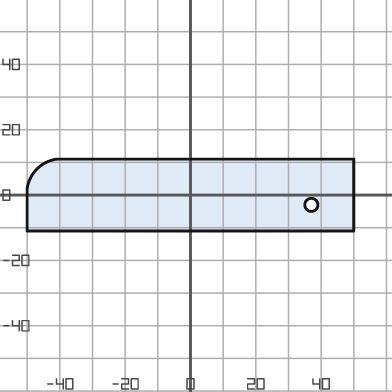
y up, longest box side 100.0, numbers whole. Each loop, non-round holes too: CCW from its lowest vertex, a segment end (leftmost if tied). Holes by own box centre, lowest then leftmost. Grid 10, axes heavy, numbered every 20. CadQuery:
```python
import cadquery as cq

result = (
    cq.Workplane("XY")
    .moveTo(-50.0, -11.0)
    .lineTo(50.0, -11.0)
    .lineTo(50.0, 11.0)
    .lineTo(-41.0, 11.0)
    .threePointArc((-47.0, 8.0), (-50.0, 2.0))
    .close()
    .moveTo(37.0, -3.0)
    .circle(2.0)
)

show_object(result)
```